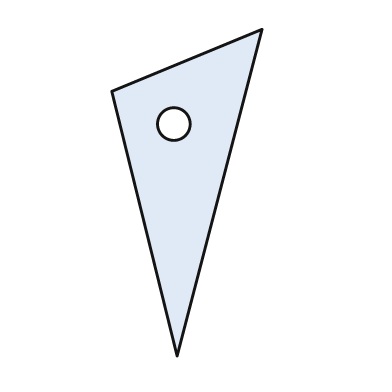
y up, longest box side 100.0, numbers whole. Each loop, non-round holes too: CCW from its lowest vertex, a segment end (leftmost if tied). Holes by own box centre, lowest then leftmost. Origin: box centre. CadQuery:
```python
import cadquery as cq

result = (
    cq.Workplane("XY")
    .moveTo(-3.0, -50.0)
    .lineTo(23.0, 50.0)
    .lineTo(-23.0, 31.0)
    .close()
    .moveTo(-4.0, 21.0)
    .circle(5.0)
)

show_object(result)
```